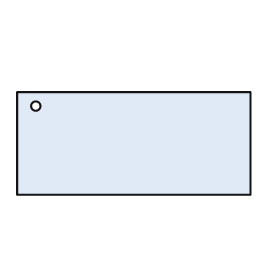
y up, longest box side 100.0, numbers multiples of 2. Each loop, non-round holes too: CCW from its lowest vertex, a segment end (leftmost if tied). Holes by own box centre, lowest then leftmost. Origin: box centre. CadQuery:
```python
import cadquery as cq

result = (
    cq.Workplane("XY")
    .moveTo(-50.0, -22.0)
    .lineTo(50.0, -22.0)
    .lineTo(50.0, 22.0)
    .lineTo(-50.0, 22.0)
    .close()
    .moveTo(-42.0, 16.0)
    .circle(2.0)
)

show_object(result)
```